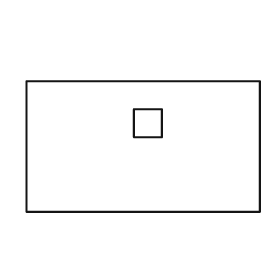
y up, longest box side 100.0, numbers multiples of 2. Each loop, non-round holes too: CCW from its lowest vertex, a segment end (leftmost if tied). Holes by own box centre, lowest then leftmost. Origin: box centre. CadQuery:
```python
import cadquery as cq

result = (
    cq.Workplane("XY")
    .moveTo(-50.0, -28.0)
    .lineTo(50.0, -28.0)
    .lineTo(50.0, 28.0)
    .lineTo(-50.0, 28.0)
    .close()
    .moveTo(-4.0, 4.0)
    .lineTo(8.0, 4.0)
    .lineTo(8.0, 16.0)
    .lineTo(-4.0, 16.0)
    .close()
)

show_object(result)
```